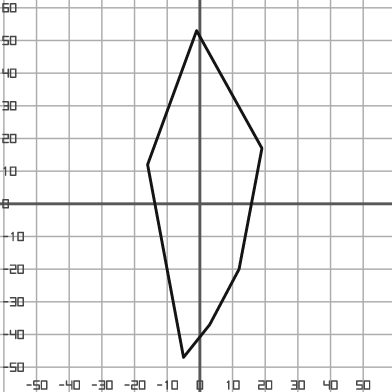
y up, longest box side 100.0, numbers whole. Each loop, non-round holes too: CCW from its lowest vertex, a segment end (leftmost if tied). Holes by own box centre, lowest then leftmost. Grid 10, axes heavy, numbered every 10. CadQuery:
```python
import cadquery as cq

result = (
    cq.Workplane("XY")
    .moveTo(-5.0, -47.0)
    .lineTo(3.0, -37.0)
    .lineTo(12.0, -20.0)
    .lineTo(19.0, 17.0)
    .lineTo(-1.0, 53.0)
    .lineTo(-16.0, 12.0)
    .close()
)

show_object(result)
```